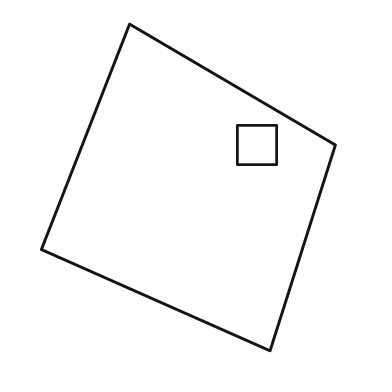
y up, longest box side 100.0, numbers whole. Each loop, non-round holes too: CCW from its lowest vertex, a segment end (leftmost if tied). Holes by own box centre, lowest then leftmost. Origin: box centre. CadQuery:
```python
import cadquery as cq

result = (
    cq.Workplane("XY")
    .moveTo(25.0, -50.0)
    .lineTo(45.0, 13.0)
    .lineTo(-18.0, 50.0)
    .lineTo(-45.0, -19.0)
    .close()
    .moveTo(15.0, 7.0)
    .lineTo(27.0, 7.0)
    .lineTo(27.0, 19.0)
    .lineTo(15.0, 19.0)
    .close()
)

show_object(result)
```